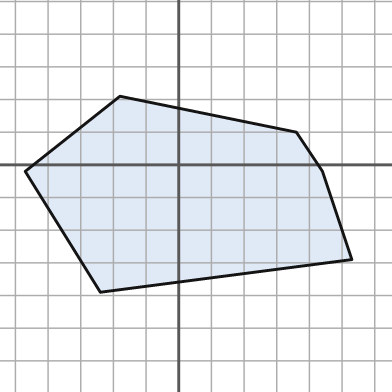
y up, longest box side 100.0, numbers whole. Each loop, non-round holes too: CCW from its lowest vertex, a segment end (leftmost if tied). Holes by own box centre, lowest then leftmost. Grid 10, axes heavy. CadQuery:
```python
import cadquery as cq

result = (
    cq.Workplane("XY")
    .moveTo(-24.0, -39.0)
    .lineTo(53.0, -29.0)
    .lineTo(44.0, -2.0)
    .lineTo(36.0, 10.0)
    .lineTo(-18.0, 21.0)
    .lineTo(-47.0, -2.0)
    .close()
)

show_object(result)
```